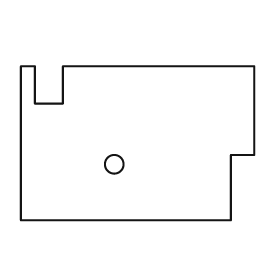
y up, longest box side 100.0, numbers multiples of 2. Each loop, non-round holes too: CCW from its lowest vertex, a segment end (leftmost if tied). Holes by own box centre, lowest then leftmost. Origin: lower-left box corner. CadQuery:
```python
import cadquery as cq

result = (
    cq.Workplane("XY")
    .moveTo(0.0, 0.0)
    .lineTo(90.0, 0.0)
    .lineTo(90.0, 28.0)
    .lineTo(100.0, 28.0)
    .lineTo(100.0, 66.0)
    .lineTo(18.0, 66.0)
    .lineTo(18.0, 50.0)
    .lineTo(6.0, 50.0)
    .lineTo(6.0, 66.0)
    .lineTo(0.0, 66.0)
    .close()
    .moveTo(40.0, 24.0)
    .circle(4.0)
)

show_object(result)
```